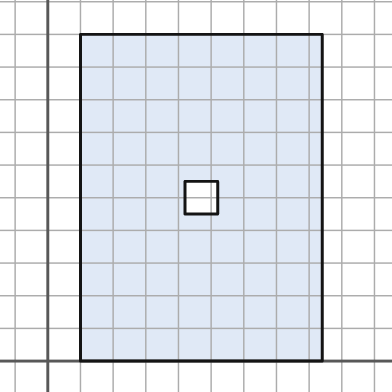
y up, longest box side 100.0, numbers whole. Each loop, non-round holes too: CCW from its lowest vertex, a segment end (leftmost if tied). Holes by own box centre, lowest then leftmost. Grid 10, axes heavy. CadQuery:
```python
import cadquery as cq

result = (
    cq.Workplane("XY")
    .moveTo(10.0, 0.0)
    .lineTo(84.0, 0.0)
    .lineTo(84.0, 100.0)
    .lineTo(10.0, 100.0)
    .close()
    .moveTo(42.0, 45.0)
    .lineTo(52.0, 45.0)
    .lineTo(52.0, 55.0)
    .lineTo(42.0, 55.0)
    .close()
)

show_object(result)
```